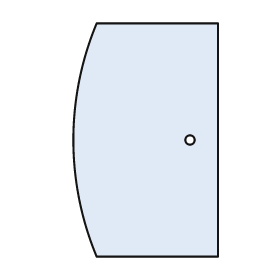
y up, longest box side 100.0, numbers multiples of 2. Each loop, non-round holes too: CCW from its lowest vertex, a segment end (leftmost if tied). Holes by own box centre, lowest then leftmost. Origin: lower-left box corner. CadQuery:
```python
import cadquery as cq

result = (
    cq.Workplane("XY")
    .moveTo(10.0, 0.0)
    .lineTo(62.0, 0.0)
    .lineTo(62.0, 100.0)
    .lineTo(10.0, 100.0)
    .threePointArc((0.0, 50.0), (10.0, 0.0))
    .close()
    .moveTo(50.0, 50.0)
    .circle(2.0)
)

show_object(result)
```